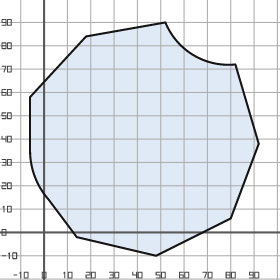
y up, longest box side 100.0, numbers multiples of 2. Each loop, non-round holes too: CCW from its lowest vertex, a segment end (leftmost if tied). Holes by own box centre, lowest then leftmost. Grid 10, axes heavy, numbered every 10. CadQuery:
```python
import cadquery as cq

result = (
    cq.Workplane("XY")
    .moveTo(48.0, -10.0)
    .lineTo(80.0, 6.0)
    .lineTo(92.0, 38.0)
    .lineTo(82.0, 72.0)
    .threePointArc((64.0, 76.0), (52.0, 90.0))
    .lineTo(18.0, 84.0)
    .lineTo(-6.0, 58.0)
    .lineTo(-6.0, 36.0)
    .threePointArc((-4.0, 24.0), (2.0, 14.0))
    .lineTo(14.0, -2.0)
    .close()
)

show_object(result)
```